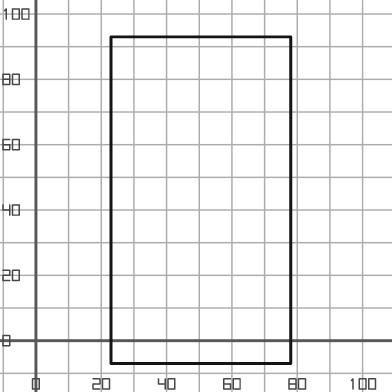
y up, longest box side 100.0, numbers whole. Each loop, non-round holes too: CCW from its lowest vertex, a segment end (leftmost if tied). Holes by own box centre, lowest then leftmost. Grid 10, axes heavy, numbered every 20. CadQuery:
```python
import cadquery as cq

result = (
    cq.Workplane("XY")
    .moveTo(23.0, -7.0)
    .lineTo(78.0, -7.0)
    .lineTo(78.0, 93.0)
    .lineTo(23.0, 93.0)
    .close()
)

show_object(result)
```